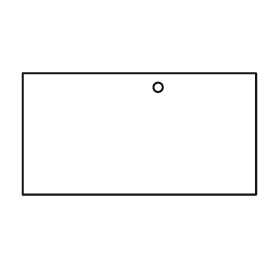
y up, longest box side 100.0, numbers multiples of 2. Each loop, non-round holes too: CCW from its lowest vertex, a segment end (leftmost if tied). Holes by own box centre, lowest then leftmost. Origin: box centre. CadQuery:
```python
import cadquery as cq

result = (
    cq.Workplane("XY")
    .moveTo(-50.0, -26.0)
    .lineTo(50.0, -26.0)
    .lineTo(50.0, 26.0)
    .lineTo(-50.0, 26.0)
    .close()
    .moveTo(8.0, 20.0)
    .circle(2.0)
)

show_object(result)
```